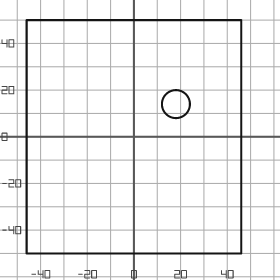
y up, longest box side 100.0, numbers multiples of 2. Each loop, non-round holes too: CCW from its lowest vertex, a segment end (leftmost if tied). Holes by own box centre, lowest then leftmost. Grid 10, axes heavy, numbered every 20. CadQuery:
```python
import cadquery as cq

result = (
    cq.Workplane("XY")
    .moveTo(-46.0, -50.0)
    .lineTo(46.0, -50.0)
    .lineTo(46.0, 50.0)
    .lineTo(-46.0, 50.0)
    .close()
    .moveTo(18.0, 14.0)
    .circle(6.0)
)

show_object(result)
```